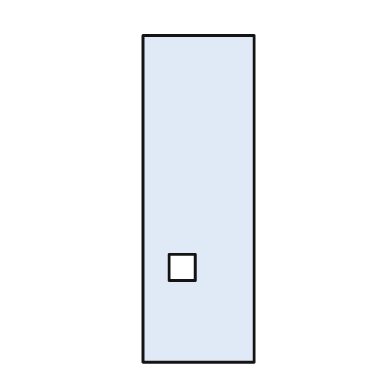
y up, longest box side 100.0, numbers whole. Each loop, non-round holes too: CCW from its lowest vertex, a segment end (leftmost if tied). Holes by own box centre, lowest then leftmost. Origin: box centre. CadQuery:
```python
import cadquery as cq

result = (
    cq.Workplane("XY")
    .moveTo(-17.0, -50.0)
    .lineTo(17.0, -50.0)
    .lineTo(17.0, 50.0)
    .lineTo(-17.0, 50.0)
    .close()
    .moveTo(-9.0, -25.0)
    .lineTo(-1.0, -25.0)
    .lineTo(-1.0, -17.0)
    .lineTo(-9.0, -17.0)
    .close()
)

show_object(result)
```